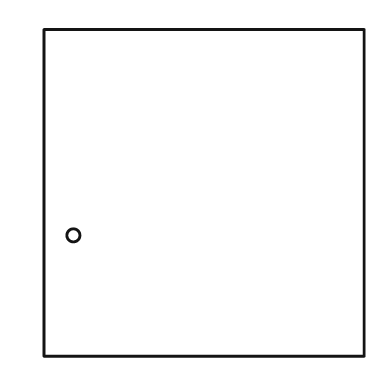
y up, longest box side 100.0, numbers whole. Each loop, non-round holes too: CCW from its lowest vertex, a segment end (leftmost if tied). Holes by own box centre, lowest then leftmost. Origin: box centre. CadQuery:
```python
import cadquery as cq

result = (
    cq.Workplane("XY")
    .moveTo(-49.0, -50.0)
    .lineTo(49.0, -50.0)
    .lineTo(49.0, 50.0)
    .lineTo(-49.0, 50.0)
    .close()
    .moveTo(-40.0, -13.0)
    .circle(2.0)
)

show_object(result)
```